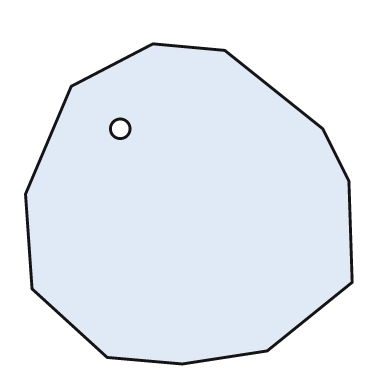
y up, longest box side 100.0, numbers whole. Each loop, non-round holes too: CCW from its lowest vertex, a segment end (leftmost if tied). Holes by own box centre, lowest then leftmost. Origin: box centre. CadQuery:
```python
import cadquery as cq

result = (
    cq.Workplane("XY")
    .moveTo(-2.0, -49.0)
    .lineTo(24.0, -45.0)
    .lineTo(50.0, -24.0)
    .lineTo(49.0, 7.0)
    .lineTo(41.0, 23.0)
    .lineTo(11.0, 47.0)
    .lineTo(-11.0, 49.0)
    .lineTo(-36.0, 36.0)
    .lineTo(-50.0, 3.0)
    .lineTo(-48.0, -26.0)
    .lineTo(-25.0, -47.0)
    .close()
    .moveTo(-21.0, 23.0)
    .circle(3.0)
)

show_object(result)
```